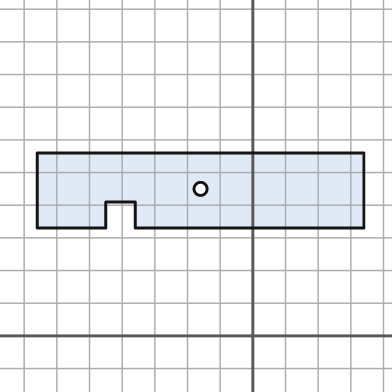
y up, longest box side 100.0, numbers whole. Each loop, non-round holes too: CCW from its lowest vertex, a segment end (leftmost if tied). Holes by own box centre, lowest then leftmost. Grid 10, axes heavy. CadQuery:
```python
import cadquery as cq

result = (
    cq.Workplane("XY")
    .moveTo(-66.0, 33.0)
    .lineTo(-45.0, 33.0)
    .lineTo(-45.0, 41.0)
    .lineTo(-36.0, 41.0)
    .lineTo(-36.0, 33.0)
    .lineTo(34.0, 33.0)
    .lineTo(34.0, 56.0)
    .lineTo(-66.0, 56.0)
    .close()
    .moveTo(-16.0, 45.0)
    .circle(2.0)
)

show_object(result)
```